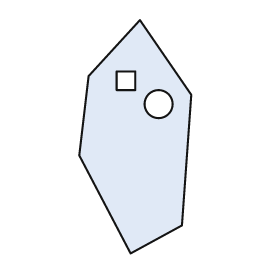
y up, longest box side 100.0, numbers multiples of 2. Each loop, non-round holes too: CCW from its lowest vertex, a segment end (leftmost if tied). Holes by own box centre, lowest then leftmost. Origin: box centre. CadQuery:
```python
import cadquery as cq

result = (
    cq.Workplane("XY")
    .moveTo(-2.0, -50.0)
    .lineTo(20.0, -38.0)
    .lineTo(24.0, 18.0)
    .lineTo(2.0, 50.0)
    .lineTo(-20.0, 26.0)
    .lineTo(-24.0, -8.0)
    .close()
    .moveTo(10.0, 14.0)
    .circle(6.0)
    .moveTo(-8.0, 20.0)
    .lineTo(0.0, 20.0)
    .lineTo(0.0, 28.0)
    .lineTo(-8.0, 28.0)
    .close()
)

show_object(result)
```